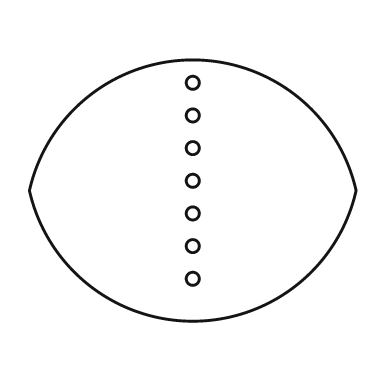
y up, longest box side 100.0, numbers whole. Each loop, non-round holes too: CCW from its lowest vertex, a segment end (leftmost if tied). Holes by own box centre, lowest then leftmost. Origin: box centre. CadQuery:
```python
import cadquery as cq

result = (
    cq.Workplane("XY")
    .moveTo(-50.0, 0.0)
    .threePointArc((0.0, -40.0), (50.0, 0.0))
    .threePointArc((0.0, 40.0), (-50.0, 0.0))
    .close()
    .moveTo(0.0, -27.0)
    .circle(2.0)
    .moveTo(0.0, -17.0)
    .circle(2.0)
    .moveTo(0.0, -7.0)
    .circle(2.0)
    .moveTo(0.0, 3.0)
    .circle(2.0)
    .moveTo(0.0, 13.0)
    .circle(2.0)
    .moveTo(0.0, 23.0)
    .circle(2.0)
    .moveTo(0.0, 33.0)
    .circle(2.0)
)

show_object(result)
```